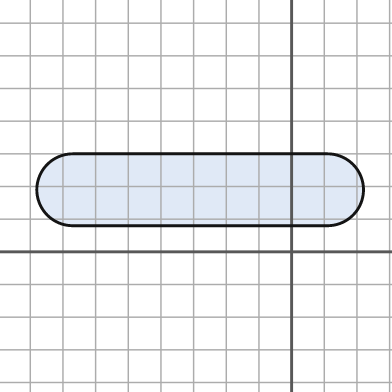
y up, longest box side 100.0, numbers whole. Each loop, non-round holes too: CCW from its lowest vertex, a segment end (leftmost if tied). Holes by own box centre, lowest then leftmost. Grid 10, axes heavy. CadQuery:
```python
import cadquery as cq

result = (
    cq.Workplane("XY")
    .moveTo(-67.0, 8.0)
    .lineTo(11.0, 8.0)
    .threePointArc((22.0, 19.0), (11.0, 30.0))
    .lineTo(-67.0, 30.0)
    .threePointArc((-78.0, 19.0), (-67.0, 8.0))
    .close()
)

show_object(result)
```